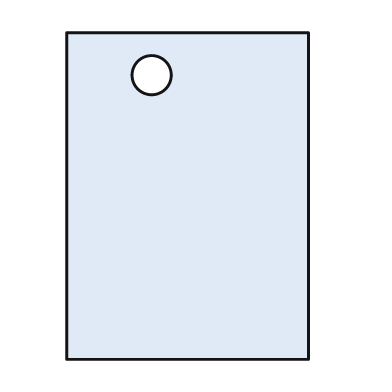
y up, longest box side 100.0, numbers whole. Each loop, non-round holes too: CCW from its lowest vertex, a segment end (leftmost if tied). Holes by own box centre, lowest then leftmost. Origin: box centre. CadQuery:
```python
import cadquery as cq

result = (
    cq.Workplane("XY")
    .moveTo(-37.0, -50.0)
    .lineTo(37.0, -50.0)
    .lineTo(37.0, 50.0)
    .lineTo(-37.0, 50.0)
    .close()
    .moveTo(-11.0, 37.0)
    .circle(6.0)
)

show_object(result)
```